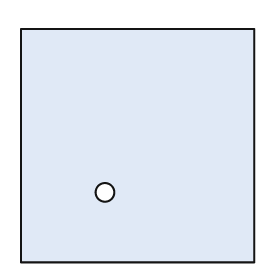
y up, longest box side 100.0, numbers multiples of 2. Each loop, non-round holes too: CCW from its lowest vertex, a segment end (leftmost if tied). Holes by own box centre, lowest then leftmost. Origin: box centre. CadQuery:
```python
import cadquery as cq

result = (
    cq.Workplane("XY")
    .moveTo(-50.0, -50.0)
    .lineTo(50.0, -50.0)
    .lineTo(50.0, 50.0)
    .lineTo(-50.0, 50.0)
    .close()
    .moveTo(-14.0, -20.0)
    .circle(4.0)
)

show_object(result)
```